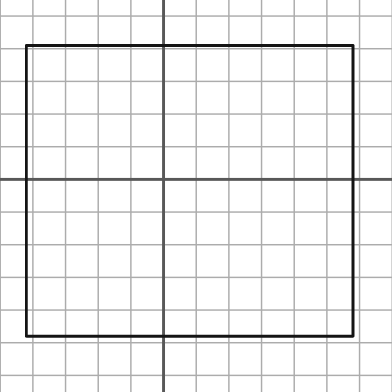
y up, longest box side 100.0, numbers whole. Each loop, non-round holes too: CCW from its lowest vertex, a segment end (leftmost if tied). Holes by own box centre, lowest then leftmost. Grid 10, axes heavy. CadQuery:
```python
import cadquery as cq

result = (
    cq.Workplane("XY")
    .moveTo(-42.0, -48.0)
    .lineTo(58.0, -48.0)
    .lineTo(58.0, 41.0)
    .lineTo(-42.0, 41.0)
    .close()
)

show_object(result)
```